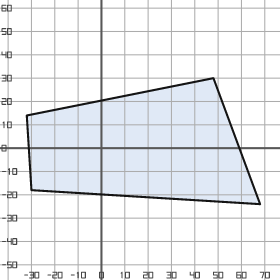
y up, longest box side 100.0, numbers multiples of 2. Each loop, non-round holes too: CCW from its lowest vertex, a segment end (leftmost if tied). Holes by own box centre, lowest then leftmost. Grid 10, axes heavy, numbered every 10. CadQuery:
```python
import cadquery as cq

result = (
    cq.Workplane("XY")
    .moveTo(68.0, -24.0)
    .lineTo(48.0, 30.0)
    .lineTo(-32.0, 14.0)
    .lineTo(-30.0, -18.0)
    .close()
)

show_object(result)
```